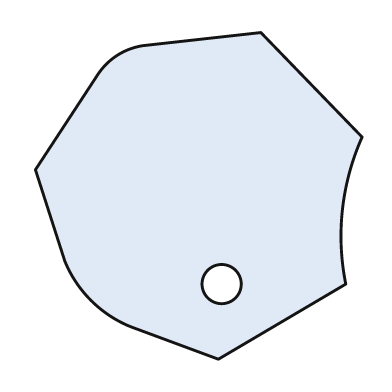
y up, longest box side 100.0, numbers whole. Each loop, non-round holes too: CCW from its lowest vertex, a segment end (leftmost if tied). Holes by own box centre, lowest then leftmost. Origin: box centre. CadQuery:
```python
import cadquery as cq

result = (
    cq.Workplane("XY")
    .moveTo(6.0, -50.0)
    .lineTo(45.0, -27.0)
    .threePointArc((44.0, -4.0), (50.0, 18.0))
    .lineTo(19.0, 50.0)
    .lineTo(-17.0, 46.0)
    .threePointArc((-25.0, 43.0), (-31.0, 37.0))
    .lineTo(-50.0, 8.0)
    .lineTo(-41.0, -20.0)
    .threePointArc((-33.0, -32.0), (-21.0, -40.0))
    .close()
    .moveTo(7.0, -27.0)
    .circle(6.0)
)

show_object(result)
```